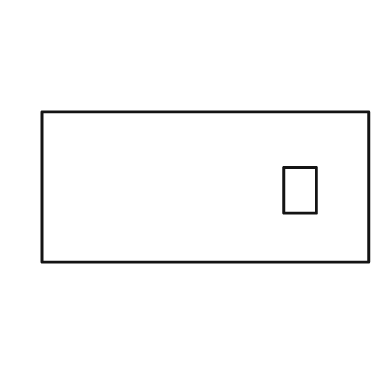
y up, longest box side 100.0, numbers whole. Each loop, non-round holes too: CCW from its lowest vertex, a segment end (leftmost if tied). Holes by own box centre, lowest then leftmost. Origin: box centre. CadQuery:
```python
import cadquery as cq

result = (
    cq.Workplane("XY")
    .moveTo(-50.0, -23.0)
    .lineTo(50.0, -23.0)
    .lineTo(50.0, 23.0)
    .lineTo(-50.0, 23.0)
    .close()
    .moveTo(24.0, -8.0)
    .lineTo(34.0, -8.0)
    .lineTo(34.0, 6.0)
    .lineTo(24.0, 6.0)
    .close()
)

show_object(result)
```